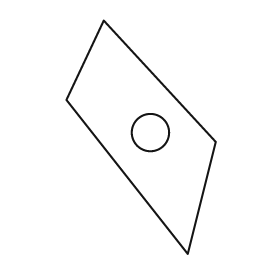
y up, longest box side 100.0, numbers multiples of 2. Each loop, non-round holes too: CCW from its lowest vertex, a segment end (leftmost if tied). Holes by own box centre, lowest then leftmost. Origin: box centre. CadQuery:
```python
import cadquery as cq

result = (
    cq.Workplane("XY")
    .moveTo(20.0, -50.0)
    .lineTo(32.0, -2.0)
    .lineTo(-16.0, 50.0)
    .lineTo(-32.0, 16.0)
    .close()
    .moveTo(4.0, 2.0)
    .circle(8.0)
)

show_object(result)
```